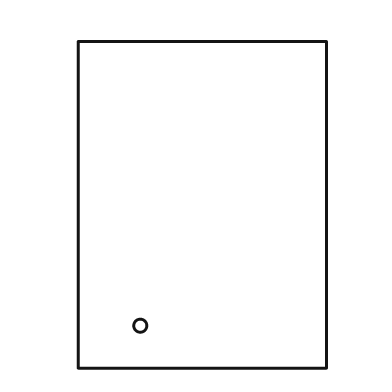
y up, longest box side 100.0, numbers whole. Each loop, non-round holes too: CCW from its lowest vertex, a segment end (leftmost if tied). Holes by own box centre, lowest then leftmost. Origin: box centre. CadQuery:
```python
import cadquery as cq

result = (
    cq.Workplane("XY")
    .moveTo(-38.0, -50.0)
    .lineTo(38.0, -50.0)
    .lineTo(38.0, 50.0)
    .lineTo(-38.0, 50.0)
    .close()
    .moveTo(-19.0, -37.0)
    .circle(2.0)
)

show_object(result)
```